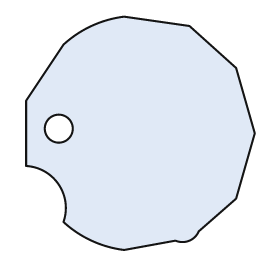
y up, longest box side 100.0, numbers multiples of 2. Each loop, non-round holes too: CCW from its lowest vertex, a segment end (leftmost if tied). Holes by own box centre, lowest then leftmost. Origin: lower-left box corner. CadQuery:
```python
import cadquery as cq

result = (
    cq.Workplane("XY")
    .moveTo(42.0, 0.0)
    .lineTo(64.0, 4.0)
    .threePointArc((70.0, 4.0), (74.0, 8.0))
    .lineTo(90.0, 22.0)
    .lineTo(98.0, 50.0)
    .lineTo(90.0, 78.0)
    .lineTo(70.0, 96.0)
    .lineTo(42.0, 100.0)
    .threePointArc((28.0, 96.0), (16.0, 88.0))
    .lineTo(0.0, 64.0)
    .lineTo(0.0, 36.0)
    .threePointArc((14.0, 28.0), (16.0, 12.0))
    .threePointArc((28.0, 4.0), (42.0, 0.0))
    .close()
    .moveTo(14.0, 52.0)
    .circle(6.0)
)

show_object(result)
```